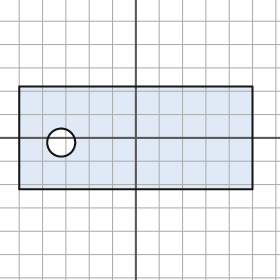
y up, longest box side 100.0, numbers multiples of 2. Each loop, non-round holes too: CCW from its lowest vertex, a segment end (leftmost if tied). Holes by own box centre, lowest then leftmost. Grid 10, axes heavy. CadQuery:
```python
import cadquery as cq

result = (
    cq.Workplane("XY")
    .moveTo(-50.0, -22.0)
    .lineTo(50.0, -22.0)
    .lineTo(50.0, 22.0)
    .lineTo(-50.0, 22.0)
    .close()
    .moveTo(-32.0, -2.0)
    .circle(6.0)
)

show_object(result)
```